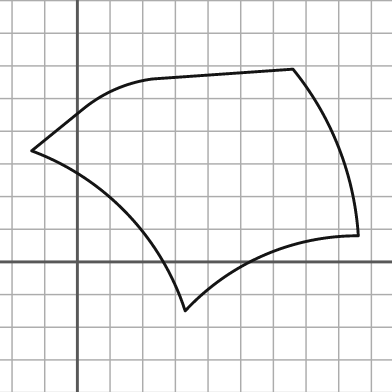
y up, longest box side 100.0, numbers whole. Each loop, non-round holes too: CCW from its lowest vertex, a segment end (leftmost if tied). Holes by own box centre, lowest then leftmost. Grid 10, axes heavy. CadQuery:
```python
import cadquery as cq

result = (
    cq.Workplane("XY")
    .moveTo(33.0, -15.0)
    .threePointArc((57.0, 2.0), (86.0, 8.0))
    .threePointArc((80.0, 35.0), (66.0, 59.0))
    .lineTo(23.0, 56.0)
    .threePointArc((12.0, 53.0), (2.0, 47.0))
    .lineTo(-14.0, 34.0)
    .threePointArc((15.0, 15.0), (33.0, -15.0))
    .close()
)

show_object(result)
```